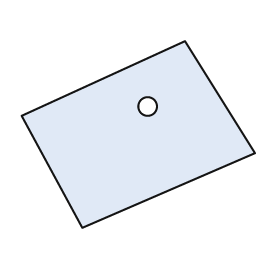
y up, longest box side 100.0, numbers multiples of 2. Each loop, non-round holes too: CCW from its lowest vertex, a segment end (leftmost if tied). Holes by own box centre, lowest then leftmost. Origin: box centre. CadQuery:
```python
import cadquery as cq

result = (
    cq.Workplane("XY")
    .moveTo(-24.0, -40.0)
    .lineTo(50.0, -8.0)
    .lineTo(20.0, 40.0)
    .lineTo(-50.0, 8.0)
    .close()
    .moveTo(4.0, 12.0)
    .circle(4.0)
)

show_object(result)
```